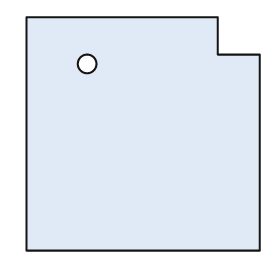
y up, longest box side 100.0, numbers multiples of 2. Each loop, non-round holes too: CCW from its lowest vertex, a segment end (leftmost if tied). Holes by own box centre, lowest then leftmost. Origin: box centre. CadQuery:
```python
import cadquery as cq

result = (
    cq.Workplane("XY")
    .moveTo(-50.0, -50.0)
    .lineTo(50.0, -50.0)
    .lineTo(50.0, 34.0)
    .lineTo(32.0, 34.0)
    .lineTo(32.0, 50.0)
    .lineTo(-50.0, 50.0)
    .close()
    .moveTo(-24.0, 30.0)
    .circle(4.0)
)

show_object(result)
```